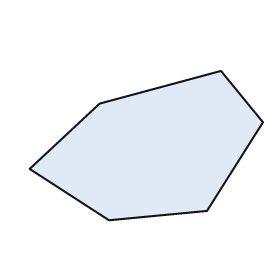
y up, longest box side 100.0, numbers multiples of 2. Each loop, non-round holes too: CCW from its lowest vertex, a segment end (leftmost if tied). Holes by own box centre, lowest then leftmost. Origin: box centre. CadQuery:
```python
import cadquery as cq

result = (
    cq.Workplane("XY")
    .moveTo(-16.0, -32.0)
    .lineTo(26.0, -28.0)
    .lineTo(50.0, 10.0)
    .lineTo(32.0, 32.0)
    .lineTo(-20.0, 18.0)
    .lineTo(-50.0, -10.0)
    .close()
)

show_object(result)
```